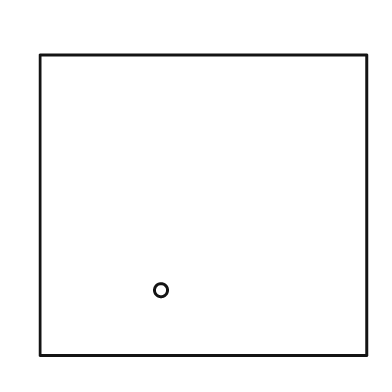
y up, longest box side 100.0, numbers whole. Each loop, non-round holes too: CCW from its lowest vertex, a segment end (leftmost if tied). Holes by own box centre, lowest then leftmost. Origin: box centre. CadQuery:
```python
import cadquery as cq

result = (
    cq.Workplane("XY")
    .moveTo(-50.0, -46.0)
    .lineTo(50.0, -46.0)
    .lineTo(50.0, 46.0)
    .lineTo(-50.0, 46.0)
    .close()
    .moveTo(-13.0, -26.0)
    .circle(2.0)
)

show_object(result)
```